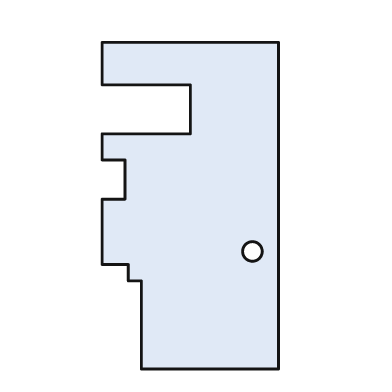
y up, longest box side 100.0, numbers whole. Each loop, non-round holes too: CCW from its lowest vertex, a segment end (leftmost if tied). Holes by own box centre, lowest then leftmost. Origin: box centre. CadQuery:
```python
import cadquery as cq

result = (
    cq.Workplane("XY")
    .moveTo(-15.0, -50.0)
    .lineTo(27.0, -50.0)
    .lineTo(27.0, 50.0)
    .lineTo(-27.0, 50.0)
    .lineTo(-27.0, 37.0)
    .lineTo(0.0, 37.0)
    .lineTo(0.0, 22.0)
    .lineTo(-27.0, 22.0)
    .lineTo(-27.0, 14.0)
    .lineTo(-20.0, 14.0)
    .lineTo(-20.0, 2.0)
    .lineTo(-27.0, 2.0)
    .lineTo(-27.0, -18.0)
    .lineTo(-19.0, -18.0)
    .lineTo(-19.0, -23.0)
    .lineTo(-15.0, -23.0)
    .close()
    .moveTo(19.0, -14.0)
    .circle(3.0)
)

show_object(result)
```